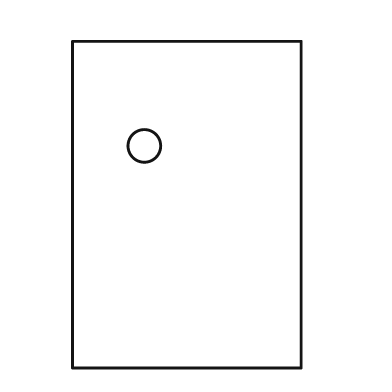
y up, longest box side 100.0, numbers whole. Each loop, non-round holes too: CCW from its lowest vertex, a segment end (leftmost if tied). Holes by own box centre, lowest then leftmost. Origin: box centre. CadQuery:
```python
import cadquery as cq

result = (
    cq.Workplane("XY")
    .moveTo(-35.0, -50.0)
    .lineTo(35.0, -50.0)
    .lineTo(35.0, 50.0)
    .lineTo(-35.0, 50.0)
    .close()
    .moveTo(-13.0, 18.0)
    .circle(5.0)
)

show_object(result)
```